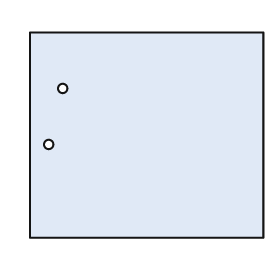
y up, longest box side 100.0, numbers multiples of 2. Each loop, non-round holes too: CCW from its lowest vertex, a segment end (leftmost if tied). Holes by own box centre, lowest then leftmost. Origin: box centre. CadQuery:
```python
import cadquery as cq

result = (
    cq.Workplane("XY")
    .moveTo(-50.0, -44.0)
    .lineTo(50.0, -44.0)
    .lineTo(50.0, 44.0)
    .lineTo(-50.0, 44.0)
    .close()
    .moveTo(-42.0, -4.0)
    .circle(2.0)
    .moveTo(-36.0, 20.0)
    .circle(2.0)
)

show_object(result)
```